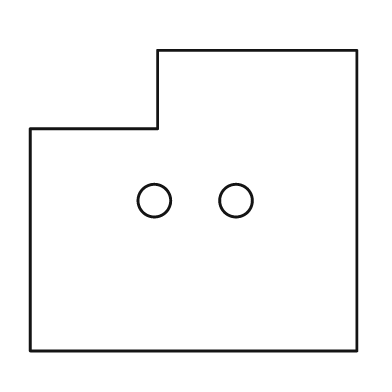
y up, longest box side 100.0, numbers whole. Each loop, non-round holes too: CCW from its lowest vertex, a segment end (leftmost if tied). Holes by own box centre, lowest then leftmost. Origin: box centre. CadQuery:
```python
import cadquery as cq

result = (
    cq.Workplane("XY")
    .moveTo(-50.0, -46.0)
    .lineTo(50.0, -46.0)
    .lineTo(50.0, 46.0)
    .lineTo(-11.0, 46.0)
    .lineTo(-11.0, 22.0)
    .lineTo(-50.0, 22.0)
    .close()
    .moveTo(-12.0, 0.0)
    .circle(5.0)
    .moveTo(13.0, 0.0)
    .circle(5.0)
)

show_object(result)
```